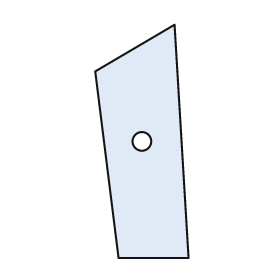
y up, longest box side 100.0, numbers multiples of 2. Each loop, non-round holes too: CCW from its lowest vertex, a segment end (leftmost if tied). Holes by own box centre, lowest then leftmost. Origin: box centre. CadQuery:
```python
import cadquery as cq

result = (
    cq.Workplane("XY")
    .moveTo(-10.0, -50.0)
    .lineTo(20.0, -50.0)
    .lineTo(14.0, 50.0)
    .lineTo(-20.0, 30.0)
    .close()
    .moveTo(0.0, 0.0)
    .circle(4.0)
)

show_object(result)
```